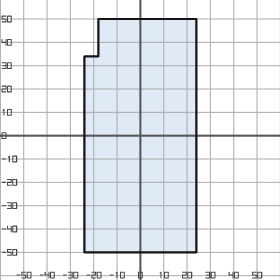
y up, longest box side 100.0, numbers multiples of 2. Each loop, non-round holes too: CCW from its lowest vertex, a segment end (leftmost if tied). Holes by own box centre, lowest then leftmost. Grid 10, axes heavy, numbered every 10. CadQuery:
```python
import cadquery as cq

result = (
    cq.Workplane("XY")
    .moveTo(-24.0, -50.0)
    .lineTo(24.0, -50.0)
    .lineTo(24.0, 50.0)
    .lineTo(-18.0, 50.0)
    .lineTo(-18.0, 34.0)
    .lineTo(-24.0, 34.0)
    .close()
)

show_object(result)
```